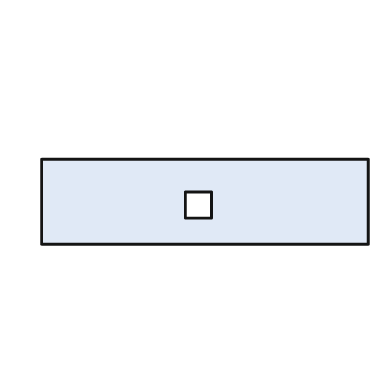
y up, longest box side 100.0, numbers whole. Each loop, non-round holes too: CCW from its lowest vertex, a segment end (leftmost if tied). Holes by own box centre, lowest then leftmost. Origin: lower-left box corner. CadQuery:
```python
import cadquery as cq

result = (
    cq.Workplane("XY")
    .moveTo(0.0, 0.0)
    .lineTo(100.0, 0.0)
    .lineTo(100.0, 26.0)
    .lineTo(0.0, 26.0)
    .close()
    .moveTo(44.0, 8.0)
    .lineTo(52.0, 8.0)
    .lineTo(52.0, 16.0)
    .lineTo(44.0, 16.0)
    .close()
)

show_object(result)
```